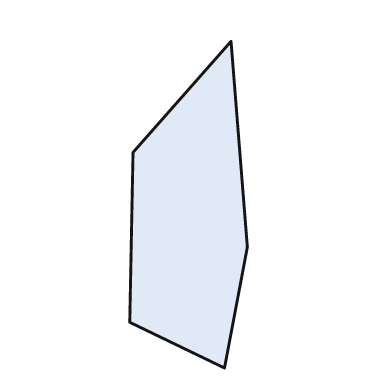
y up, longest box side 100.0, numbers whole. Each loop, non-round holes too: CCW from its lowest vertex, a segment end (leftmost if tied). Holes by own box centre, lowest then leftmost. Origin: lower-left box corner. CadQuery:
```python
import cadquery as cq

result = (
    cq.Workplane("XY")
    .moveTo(29.0, 0.0)
    .lineTo(36.0, 37.0)
    .lineTo(31.0, 100.0)
    .lineTo(1.0, 66.0)
    .lineTo(0.0, 14.0)
    .close()
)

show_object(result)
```